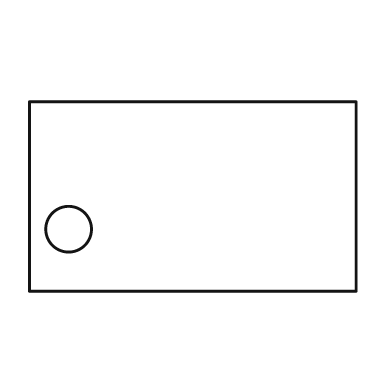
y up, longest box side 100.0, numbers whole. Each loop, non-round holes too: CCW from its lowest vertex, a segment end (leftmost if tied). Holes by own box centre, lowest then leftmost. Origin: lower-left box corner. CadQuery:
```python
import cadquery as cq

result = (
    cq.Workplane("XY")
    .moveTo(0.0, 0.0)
    .lineTo(100.0, 0.0)
    .lineTo(100.0, 58.0)
    .lineTo(0.0, 58.0)
    .close()
    .moveTo(12.0, 19.0)
    .circle(7.0)
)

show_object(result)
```